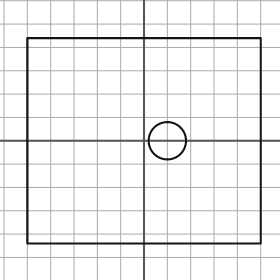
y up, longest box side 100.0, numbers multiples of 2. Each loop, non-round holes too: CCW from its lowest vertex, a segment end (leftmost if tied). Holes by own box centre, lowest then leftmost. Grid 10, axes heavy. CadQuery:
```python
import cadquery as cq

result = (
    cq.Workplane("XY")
    .moveTo(-50.0, -44.0)
    .lineTo(50.0, -44.0)
    .lineTo(50.0, 44.0)
    .lineTo(-50.0, 44.0)
    .close()
    .moveTo(10.0, 0.0)
    .circle(8.0)
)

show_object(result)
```